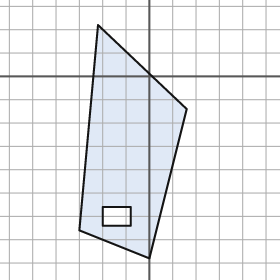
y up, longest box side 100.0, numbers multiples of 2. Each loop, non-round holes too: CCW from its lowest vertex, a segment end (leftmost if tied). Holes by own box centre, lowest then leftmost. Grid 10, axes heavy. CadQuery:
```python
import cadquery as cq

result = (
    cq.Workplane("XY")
    .moveTo(0.0, -78.0)
    .lineTo(16.0, -14.0)
    .lineTo(-22.0, 22.0)
    .lineTo(-30.0, -66.0)
    .close()
    .moveTo(-20.0, -64.0)
    .lineTo(-8.0, -64.0)
    .lineTo(-8.0, -56.0)
    .lineTo(-20.0, -56.0)
    .close()
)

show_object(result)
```